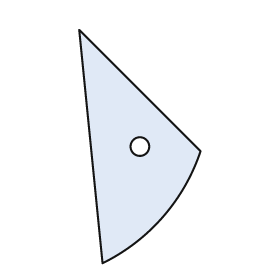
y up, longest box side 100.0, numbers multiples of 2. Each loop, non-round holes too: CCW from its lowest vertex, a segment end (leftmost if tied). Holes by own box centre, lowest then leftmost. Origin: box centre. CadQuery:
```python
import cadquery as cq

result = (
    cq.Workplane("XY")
    .moveTo(-16.0, -50.0)
    .threePointArc((10.0, -30.0), (26.0, -2.0))
    .lineTo(-26.0, 50.0)
    .close()
    .moveTo(0.0, 0.0)
    .circle(4.0)
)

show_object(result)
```